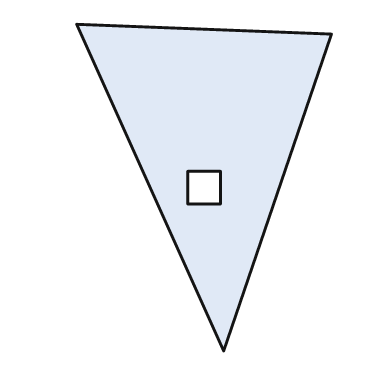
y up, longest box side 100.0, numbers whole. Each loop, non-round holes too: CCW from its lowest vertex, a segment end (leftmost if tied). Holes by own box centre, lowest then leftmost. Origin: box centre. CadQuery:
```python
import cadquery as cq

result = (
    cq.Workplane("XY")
    .moveTo(6.0, -50.0)
    .lineTo(39.0, 47.0)
    .lineTo(-39.0, 50.0)
    .close()
    .moveTo(-5.0, -5.0)
    .lineTo(5.0, -5.0)
    .lineTo(5.0, 5.0)
    .lineTo(-5.0, 5.0)
    .close()
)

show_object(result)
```